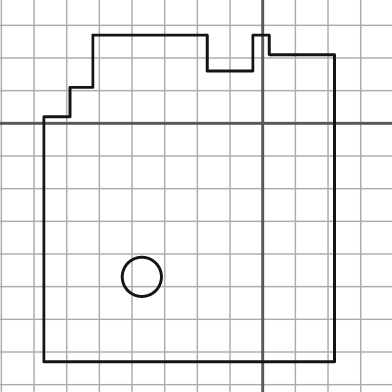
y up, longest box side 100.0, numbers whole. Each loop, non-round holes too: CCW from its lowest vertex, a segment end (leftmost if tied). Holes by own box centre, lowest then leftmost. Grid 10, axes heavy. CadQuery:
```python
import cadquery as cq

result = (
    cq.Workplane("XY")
    .moveTo(-67.0, -73.0)
    .lineTo(22.0, -73.0)
    .lineTo(22.0, 21.0)
    .lineTo(2.0, 21.0)
    .lineTo(2.0, 27.0)
    .lineTo(-3.0, 27.0)
    .lineTo(-3.0, 16.0)
    .lineTo(-17.0, 16.0)
    .lineTo(-17.0, 27.0)
    .lineTo(-52.0, 27.0)
    .lineTo(-52.0, 11.0)
    .lineTo(-59.0, 11.0)
    .lineTo(-59.0, 2.0)
    .lineTo(-67.0, 2.0)
    .close()
    .moveTo(-37.0, -47.0)
    .circle(6.0)
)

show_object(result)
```